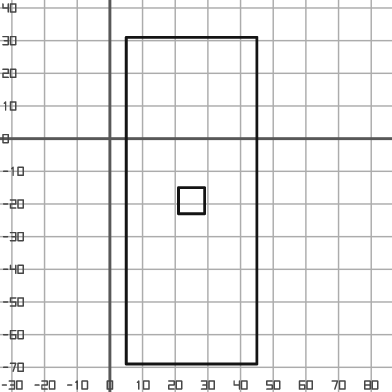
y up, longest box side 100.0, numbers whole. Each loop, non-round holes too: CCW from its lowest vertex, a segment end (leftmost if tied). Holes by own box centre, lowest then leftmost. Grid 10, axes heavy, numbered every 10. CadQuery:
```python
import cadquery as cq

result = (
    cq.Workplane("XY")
    .moveTo(5.0, -69.0)
    .lineTo(45.0, -69.0)
    .lineTo(45.0, 31.0)
    .lineTo(5.0, 31.0)
    .close()
    .moveTo(21.0, -23.0)
    .lineTo(29.0, -23.0)
    .lineTo(29.0, -15.0)
    .lineTo(21.0, -15.0)
    .close()
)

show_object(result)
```